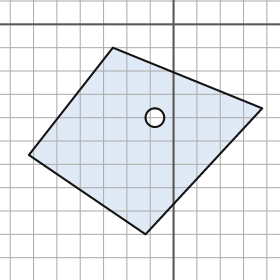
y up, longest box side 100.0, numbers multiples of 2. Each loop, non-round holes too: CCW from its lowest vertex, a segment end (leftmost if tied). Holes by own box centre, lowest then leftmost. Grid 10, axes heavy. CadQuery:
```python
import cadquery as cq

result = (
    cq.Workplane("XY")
    .moveTo(-12.0, -90.0)
    .lineTo(38.0, -36.0)
    .lineTo(-26.0, -10.0)
    .lineTo(-62.0, -56.0)
    .close()
    .moveTo(-8.0, -40.0)
    .circle(4.0)
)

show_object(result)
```